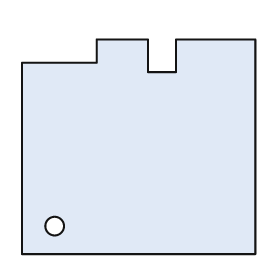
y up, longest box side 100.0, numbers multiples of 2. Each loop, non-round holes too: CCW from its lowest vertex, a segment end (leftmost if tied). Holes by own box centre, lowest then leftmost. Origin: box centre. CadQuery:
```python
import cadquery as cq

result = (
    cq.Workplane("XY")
    .moveTo(-50.0, -46.0)
    .lineTo(50.0, -46.0)
    .lineTo(50.0, 46.0)
    .lineTo(16.0, 46.0)
    .lineTo(16.0, 32.0)
    .lineTo(4.0, 32.0)
    .lineTo(4.0, 46.0)
    .lineTo(-18.0, 46.0)
    .lineTo(-18.0, 36.0)
    .lineTo(-50.0, 36.0)
    .close()
    .moveTo(-36.0, -34.0)
    .circle(4.0)
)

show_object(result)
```